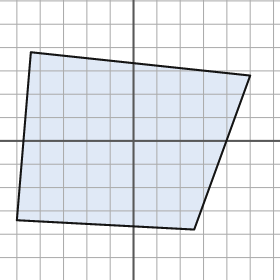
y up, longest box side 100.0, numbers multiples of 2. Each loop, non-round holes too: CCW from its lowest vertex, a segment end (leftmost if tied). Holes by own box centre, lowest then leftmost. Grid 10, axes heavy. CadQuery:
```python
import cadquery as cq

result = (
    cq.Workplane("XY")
    .moveTo(26.0, -38.0)
    .lineTo(50.0, 28.0)
    .lineTo(-44.0, 38.0)
    .lineTo(-50.0, -34.0)
    .close()
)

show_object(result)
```